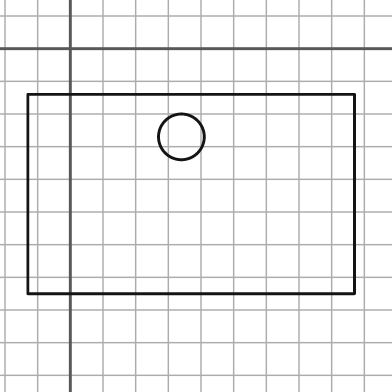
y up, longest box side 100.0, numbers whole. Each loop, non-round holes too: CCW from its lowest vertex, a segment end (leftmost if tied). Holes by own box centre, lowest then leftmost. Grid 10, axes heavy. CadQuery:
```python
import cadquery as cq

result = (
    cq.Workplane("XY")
    .moveTo(-13.0, -75.0)
    .lineTo(87.0, -75.0)
    .lineTo(87.0, -14.0)
    .lineTo(-13.0, -14.0)
    .close()
    .moveTo(34.0, -27.0)
    .circle(7.0)
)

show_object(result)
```